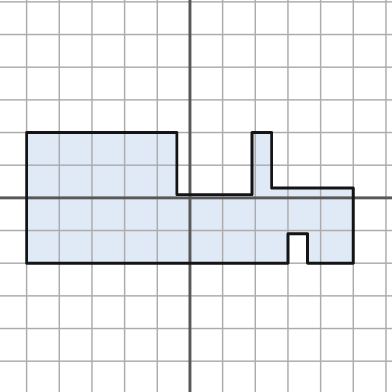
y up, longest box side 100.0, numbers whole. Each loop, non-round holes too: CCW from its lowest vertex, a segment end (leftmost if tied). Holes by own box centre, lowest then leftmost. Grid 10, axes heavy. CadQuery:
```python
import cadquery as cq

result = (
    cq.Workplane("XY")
    .moveTo(-50.0, -20.0)
    .lineTo(30.0, -20.0)
    .lineTo(30.0, -11.0)
    .lineTo(36.0, -11.0)
    .lineTo(36.0, -20.0)
    .lineTo(50.0, -20.0)
    .lineTo(50.0, 3.0)
    .lineTo(25.0, 3.0)
    .lineTo(25.0, 20.0)
    .lineTo(19.0, 20.0)
    .lineTo(19.0, 1.0)
    .lineTo(-4.0, 1.0)
    .lineTo(-4.0, 20.0)
    .lineTo(-50.0, 20.0)
    .close()
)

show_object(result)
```